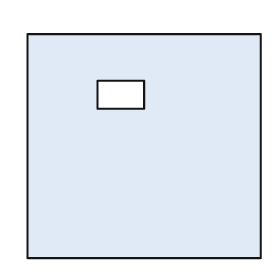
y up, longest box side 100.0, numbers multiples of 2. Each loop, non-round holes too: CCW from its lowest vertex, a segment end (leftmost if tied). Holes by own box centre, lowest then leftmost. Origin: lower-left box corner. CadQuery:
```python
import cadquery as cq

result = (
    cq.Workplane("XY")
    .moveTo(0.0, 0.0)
    .lineTo(100.0, 0.0)
    .lineTo(100.0, 96.0)
    .lineTo(0.0, 96.0)
    .close()
    .moveTo(30.0, 64.0)
    .lineTo(50.0, 64.0)
    .lineTo(50.0, 76.0)
    .lineTo(30.0, 76.0)
    .close()
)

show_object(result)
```